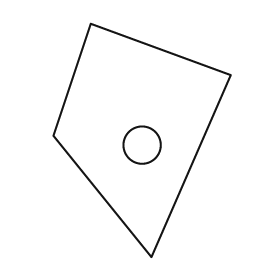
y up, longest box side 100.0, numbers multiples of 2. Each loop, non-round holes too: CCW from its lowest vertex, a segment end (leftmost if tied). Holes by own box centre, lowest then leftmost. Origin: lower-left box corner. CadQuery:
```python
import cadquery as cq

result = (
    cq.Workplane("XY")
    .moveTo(42.0, 0.0)
    .lineTo(76.0, 78.0)
    .lineTo(16.0, 100.0)
    .lineTo(0.0, 52.0)
    .close()
    .moveTo(38.0, 48.0)
    .circle(8.0)
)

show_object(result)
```